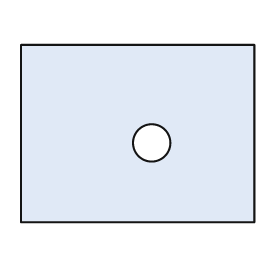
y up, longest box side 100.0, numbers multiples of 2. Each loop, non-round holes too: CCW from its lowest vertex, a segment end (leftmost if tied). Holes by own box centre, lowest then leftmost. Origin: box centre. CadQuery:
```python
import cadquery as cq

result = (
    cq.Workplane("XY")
    .moveTo(-50.0, -38.0)
    .lineTo(50.0, -38.0)
    .lineTo(50.0, 38.0)
    .lineTo(-50.0, 38.0)
    .close()
    .moveTo(6.0, -4.0)
    .circle(8.0)
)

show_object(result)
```